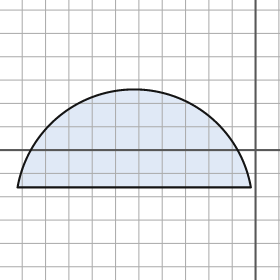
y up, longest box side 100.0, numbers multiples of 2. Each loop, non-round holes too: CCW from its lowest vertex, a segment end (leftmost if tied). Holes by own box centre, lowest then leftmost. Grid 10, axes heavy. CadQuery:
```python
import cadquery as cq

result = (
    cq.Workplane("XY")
    .moveTo(-102.0, -16.0)
    .lineTo(-2.0, -16.0)
    .threePointArc((-52.0, 26.0), (-102.0, -16.0))
    .close()
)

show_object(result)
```